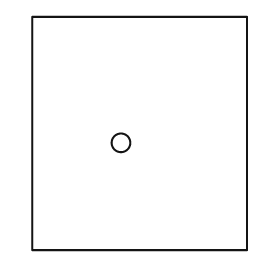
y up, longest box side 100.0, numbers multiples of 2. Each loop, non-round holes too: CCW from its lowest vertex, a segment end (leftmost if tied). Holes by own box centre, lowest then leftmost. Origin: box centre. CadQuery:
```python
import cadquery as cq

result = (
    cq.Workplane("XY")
    .moveTo(-46.0, -50.0)
    .lineTo(46.0, -50.0)
    .lineTo(46.0, 50.0)
    .lineTo(-46.0, 50.0)
    .close()
    .moveTo(-8.0, -4.0)
    .circle(4.0)
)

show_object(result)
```